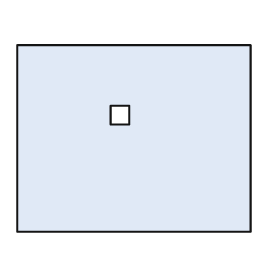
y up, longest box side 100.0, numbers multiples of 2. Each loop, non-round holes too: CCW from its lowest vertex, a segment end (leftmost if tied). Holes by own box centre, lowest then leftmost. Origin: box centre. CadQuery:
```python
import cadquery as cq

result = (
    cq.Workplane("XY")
    .moveTo(-50.0, -40.0)
    .lineTo(50.0, -40.0)
    .lineTo(50.0, 40.0)
    .lineTo(-50.0, 40.0)
    .close()
    .moveTo(-10.0, 6.0)
    .lineTo(-2.0, 6.0)
    .lineTo(-2.0, 14.0)
    .lineTo(-10.0, 14.0)
    .close()
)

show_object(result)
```